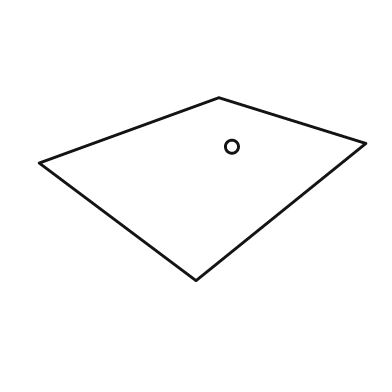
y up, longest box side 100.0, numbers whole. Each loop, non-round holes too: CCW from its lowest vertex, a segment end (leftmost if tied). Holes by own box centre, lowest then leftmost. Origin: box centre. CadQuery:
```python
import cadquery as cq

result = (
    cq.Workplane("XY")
    .moveTo(-2.0, -28.0)
    .lineTo(50.0, 14.0)
    .lineTo(5.0, 28.0)
    .lineTo(-50.0, 8.0)
    .close()
    .moveTo(9.0, 13.0)
    .circle(2.0)
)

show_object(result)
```